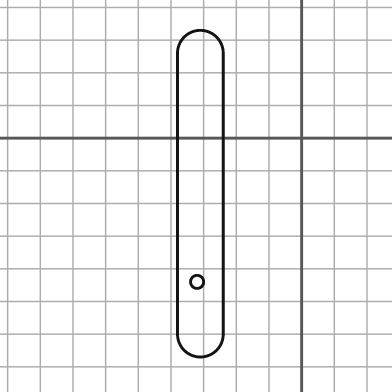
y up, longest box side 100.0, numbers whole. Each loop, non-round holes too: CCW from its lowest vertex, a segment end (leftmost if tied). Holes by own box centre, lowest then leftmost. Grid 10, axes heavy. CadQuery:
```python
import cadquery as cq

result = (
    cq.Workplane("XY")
    .moveTo(-38.0, -60.0)
    .threePointArc((-31.0, -67.0), (-24.0, -60.0))
    .lineTo(-24.0, 26.0)
    .threePointArc((-31.0, 33.0), (-38.0, 26.0))
    .close()
    .moveTo(-32.0, -44.0)
    .circle(2.0)
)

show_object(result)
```